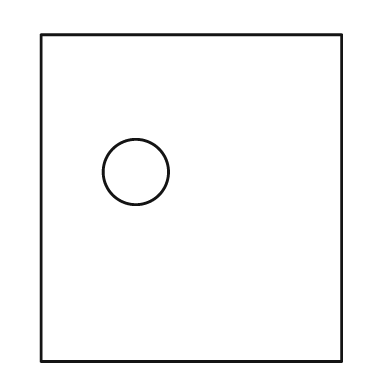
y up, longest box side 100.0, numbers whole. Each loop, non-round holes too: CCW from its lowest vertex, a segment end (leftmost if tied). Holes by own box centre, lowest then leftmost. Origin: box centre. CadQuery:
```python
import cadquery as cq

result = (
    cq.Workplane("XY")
    .moveTo(-46.0, -50.0)
    .lineTo(46.0, -50.0)
    .lineTo(46.0, 50.0)
    .lineTo(-46.0, 50.0)
    .close()
    .moveTo(-17.0, 8.0)
    .circle(10.0)
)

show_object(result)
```